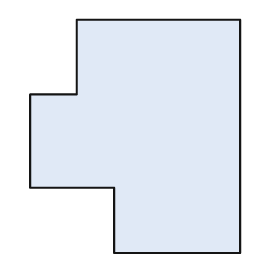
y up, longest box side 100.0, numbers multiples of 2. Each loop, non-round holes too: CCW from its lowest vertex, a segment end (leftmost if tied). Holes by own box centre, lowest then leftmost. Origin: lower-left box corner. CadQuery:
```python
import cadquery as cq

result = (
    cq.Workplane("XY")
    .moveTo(36.0, 0.0)
    .lineTo(90.0, 0.0)
    .lineTo(90.0, 100.0)
    .lineTo(20.0, 100.0)
    .lineTo(20.0, 68.0)
    .lineTo(0.0, 68.0)
    .lineTo(0.0, 28.0)
    .lineTo(36.0, 28.0)
    .close()
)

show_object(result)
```